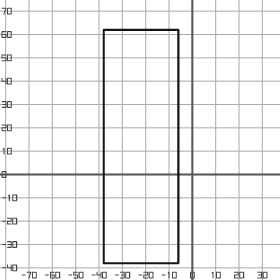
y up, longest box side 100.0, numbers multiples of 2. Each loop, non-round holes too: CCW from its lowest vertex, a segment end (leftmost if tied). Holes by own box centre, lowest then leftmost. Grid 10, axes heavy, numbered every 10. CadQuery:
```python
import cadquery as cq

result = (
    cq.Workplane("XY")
    .moveTo(-38.0, -38.0)
    .lineTo(-6.0, -38.0)
    .lineTo(-6.0, 62.0)
    .lineTo(-38.0, 62.0)
    .close()
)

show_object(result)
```